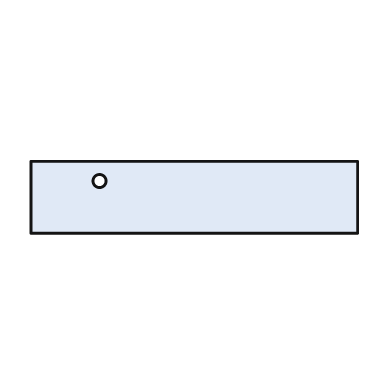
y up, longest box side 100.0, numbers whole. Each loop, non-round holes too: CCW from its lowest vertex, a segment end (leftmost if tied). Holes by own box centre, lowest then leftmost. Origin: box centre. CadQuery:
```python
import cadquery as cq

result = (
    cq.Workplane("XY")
    .moveTo(-50.0, -11.0)
    .lineTo(50.0, -11.0)
    .lineTo(50.0, 11.0)
    .lineTo(-50.0, 11.0)
    .close()
    .moveTo(-29.0, 5.0)
    .circle(2.0)
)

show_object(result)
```